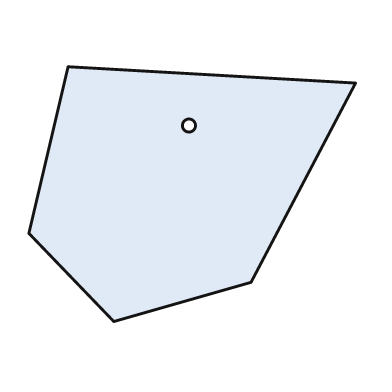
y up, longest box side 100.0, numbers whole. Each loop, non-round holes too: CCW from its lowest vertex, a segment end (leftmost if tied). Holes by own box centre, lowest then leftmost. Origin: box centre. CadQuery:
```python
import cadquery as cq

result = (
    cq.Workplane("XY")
    .moveTo(-24.0, -39.0)
    .lineTo(18.0, -27.0)
    .lineTo(50.0, 34.0)
    .lineTo(-38.0, 39.0)
    .lineTo(-50.0, -12.0)
    .close()
    .moveTo(-1.0, 21.0)
    .circle(2.0)
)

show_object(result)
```